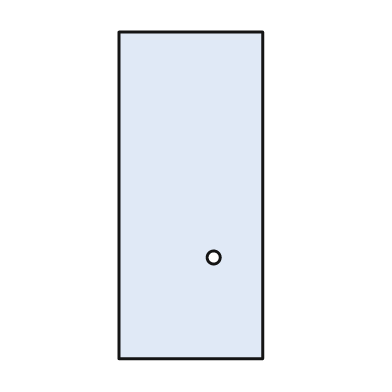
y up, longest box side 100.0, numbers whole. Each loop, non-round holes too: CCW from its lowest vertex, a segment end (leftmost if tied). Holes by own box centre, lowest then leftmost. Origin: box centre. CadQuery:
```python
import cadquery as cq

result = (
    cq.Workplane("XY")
    .moveTo(-22.0, -50.0)
    .lineTo(22.0, -50.0)
    .lineTo(22.0, 50.0)
    .lineTo(-22.0, 50.0)
    .close()
    .moveTo(7.0, -19.0)
    .circle(2.0)
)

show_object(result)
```